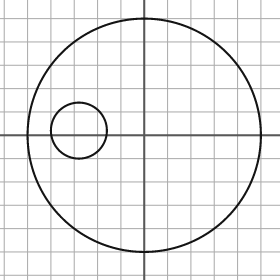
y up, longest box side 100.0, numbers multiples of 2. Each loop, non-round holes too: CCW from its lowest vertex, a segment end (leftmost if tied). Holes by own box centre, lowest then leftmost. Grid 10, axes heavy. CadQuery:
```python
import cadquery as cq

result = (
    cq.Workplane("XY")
    .moveTo(0.0, 0.0)
    .circle(50.0)
    .moveTo(-28.0, 2.0)
    .circle(12.0)
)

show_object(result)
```